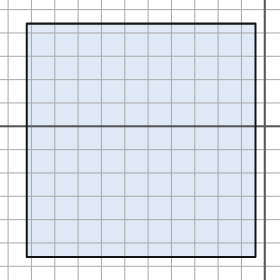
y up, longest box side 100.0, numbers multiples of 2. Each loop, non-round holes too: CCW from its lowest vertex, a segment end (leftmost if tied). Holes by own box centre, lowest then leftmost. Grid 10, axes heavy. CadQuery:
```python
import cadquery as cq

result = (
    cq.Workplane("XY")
    .moveTo(-102.0, -56.0)
    .lineTo(-4.0, -56.0)
    .lineTo(-4.0, 44.0)
    .lineTo(-102.0, 44.0)
    .close()
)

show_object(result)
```